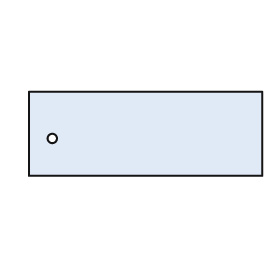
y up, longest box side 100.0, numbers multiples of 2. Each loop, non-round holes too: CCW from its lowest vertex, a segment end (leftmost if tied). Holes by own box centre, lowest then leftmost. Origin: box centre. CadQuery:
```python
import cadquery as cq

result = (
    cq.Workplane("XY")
    .moveTo(-50.0, -18.0)
    .lineTo(50.0, -18.0)
    .lineTo(50.0, 18.0)
    .lineTo(-50.0, 18.0)
    .close()
    .moveTo(-40.0, -2.0)
    .circle(2.0)
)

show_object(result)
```